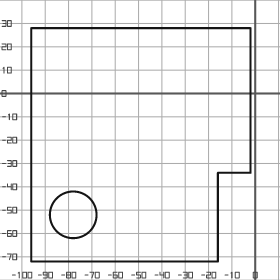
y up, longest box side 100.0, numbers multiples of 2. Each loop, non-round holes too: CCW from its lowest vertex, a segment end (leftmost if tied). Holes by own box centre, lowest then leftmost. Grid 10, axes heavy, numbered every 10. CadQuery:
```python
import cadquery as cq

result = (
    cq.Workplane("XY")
    .moveTo(-96.0, -72.0)
    .lineTo(-16.0, -72.0)
    .lineTo(-16.0, -34.0)
    .lineTo(-2.0, -34.0)
    .lineTo(-2.0, 28.0)
    .lineTo(-96.0, 28.0)
    .close()
    .moveTo(-78.0, -52.0)
    .circle(10.0)
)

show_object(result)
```